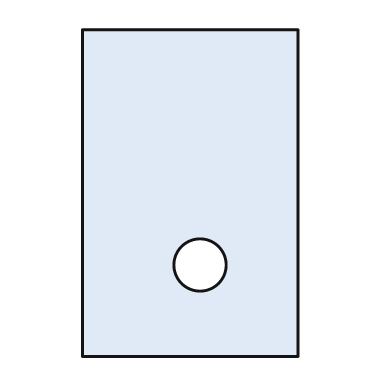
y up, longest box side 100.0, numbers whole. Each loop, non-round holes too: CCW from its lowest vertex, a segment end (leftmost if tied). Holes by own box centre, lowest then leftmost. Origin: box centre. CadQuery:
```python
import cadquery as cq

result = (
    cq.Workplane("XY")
    .moveTo(-33.0, -50.0)
    .lineTo(33.0, -50.0)
    .lineTo(33.0, 50.0)
    .lineTo(-33.0, 50.0)
    .close()
    .moveTo(3.0, -22.0)
    .circle(8.0)
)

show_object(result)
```